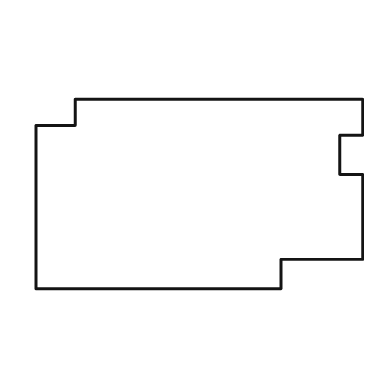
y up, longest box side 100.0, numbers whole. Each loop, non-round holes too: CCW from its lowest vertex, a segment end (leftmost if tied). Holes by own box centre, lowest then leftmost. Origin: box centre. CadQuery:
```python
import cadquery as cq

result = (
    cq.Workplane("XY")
    .moveTo(-50.0, -29.0)
    .lineTo(25.0, -29.0)
    .lineTo(25.0, -20.0)
    .lineTo(50.0, -20.0)
    .lineTo(50.0, 6.0)
    .lineTo(43.0, 6.0)
    .lineTo(43.0, 18.0)
    .lineTo(50.0, 18.0)
    .lineTo(50.0, 29.0)
    .lineTo(-38.0, 29.0)
    .lineTo(-38.0, 21.0)
    .lineTo(-50.0, 21.0)
    .close()
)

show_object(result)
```